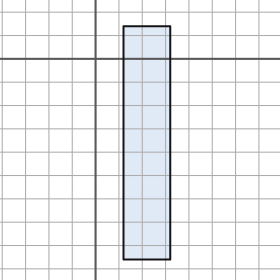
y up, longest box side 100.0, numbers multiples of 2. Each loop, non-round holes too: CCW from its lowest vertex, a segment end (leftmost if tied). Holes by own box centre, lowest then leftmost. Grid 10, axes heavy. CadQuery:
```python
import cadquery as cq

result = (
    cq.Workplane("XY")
    .moveTo(12.0, -86.0)
    .lineTo(32.0, -86.0)
    .lineTo(32.0, 14.0)
    .lineTo(12.0, 14.0)
    .close()
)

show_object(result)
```